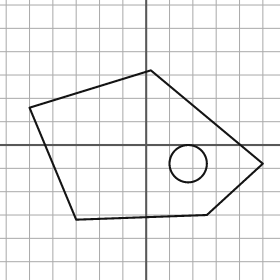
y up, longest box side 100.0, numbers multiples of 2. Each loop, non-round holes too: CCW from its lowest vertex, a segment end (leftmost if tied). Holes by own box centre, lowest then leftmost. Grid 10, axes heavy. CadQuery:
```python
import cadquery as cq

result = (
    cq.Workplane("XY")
    .moveTo(-30.0, -32.0)
    .lineTo(26.0, -30.0)
    .lineTo(50.0, -8.0)
    .lineTo(2.0, 32.0)
    .lineTo(-50.0, 16.0)
    .close()
    .moveTo(18.0, -8.0)
    .circle(8.0)
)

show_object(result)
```